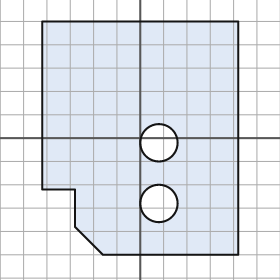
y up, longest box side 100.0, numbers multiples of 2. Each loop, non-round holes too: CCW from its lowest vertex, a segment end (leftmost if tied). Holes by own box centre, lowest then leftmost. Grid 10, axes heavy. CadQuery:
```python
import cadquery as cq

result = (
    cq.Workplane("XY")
    .moveTo(-16.0, -50.0)
    .lineTo(42.0, -50.0)
    .lineTo(42.0, 50.0)
    .lineTo(-42.0, 50.0)
    .lineTo(-42.0, -22.0)
    .lineTo(-28.0, -22.0)
    .lineTo(-28.0, -38.0)
    .close()
    .moveTo(8.0, -28.0)
    .circle(8.0)
    .moveTo(8.0, -2.0)
    .circle(8.0)
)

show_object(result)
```